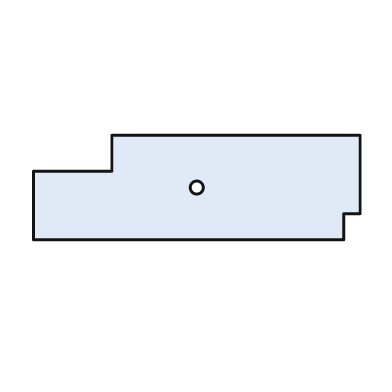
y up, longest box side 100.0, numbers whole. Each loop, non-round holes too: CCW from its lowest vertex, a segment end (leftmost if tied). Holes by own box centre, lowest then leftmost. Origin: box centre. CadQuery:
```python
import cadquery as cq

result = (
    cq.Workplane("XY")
    .moveTo(-50.0, -16.0)
    .lineTo(45.0, -16.0)
    .lineTo(45.0, -8.0)
    .lineTo(50.0, -8.0)
    .lineTo(50.0, 16.0)
    .lineTo(-26.0, 16.0)
    .lineTo(-26.0, 5.0)
    .lineTo(-50.0, 5.0)
    .close()
    .moveTo(0.0, 0.0)
    .circle(2.0)
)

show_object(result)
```